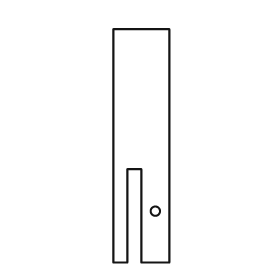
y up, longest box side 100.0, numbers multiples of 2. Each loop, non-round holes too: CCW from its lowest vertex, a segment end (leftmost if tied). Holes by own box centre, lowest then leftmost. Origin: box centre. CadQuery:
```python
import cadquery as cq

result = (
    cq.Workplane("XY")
    .moveTo(-12.0, -50.0)
    .lineTo(-6.0, -50.0)
    .lineTo(-6.0, -10.0)
    .lineTo(0.0, -10.0)
    .lineTo(0.0, -50.0)
    .lineTo(12.0, -50.0)
    .lineTo(12.0, 50.0)
    .lineTo(-12.0, 50.0)
    .close()
    .moveTo(6.0, -28.0)
    .circle(2.0)
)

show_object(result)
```